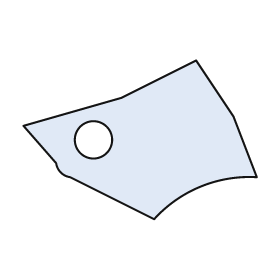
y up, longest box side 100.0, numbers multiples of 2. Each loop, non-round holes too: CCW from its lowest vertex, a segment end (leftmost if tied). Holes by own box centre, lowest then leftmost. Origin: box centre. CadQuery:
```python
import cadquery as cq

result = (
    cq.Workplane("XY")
    .moveTo(6.0, -34.0)
    .threePointArc((26.0, -20.0), (50.0, -16.0))
    .lineTo(40.0, 10.0)
    .lineTo(24.0, 34.0)
    .lineTo(-8.0, 18.0)
    .lineTo(-50.0, 6.0)
    .lineTo(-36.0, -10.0)
    .threePointArc((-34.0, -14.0), (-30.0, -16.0))
    .close()
    .moveTo(-20.0, 0.0)
    .circle(8.0)
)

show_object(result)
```